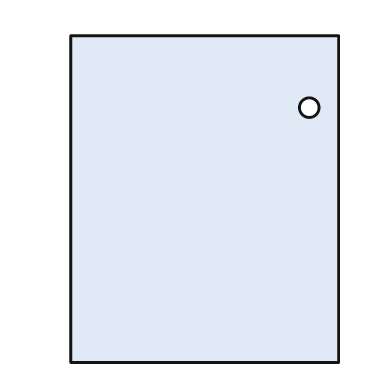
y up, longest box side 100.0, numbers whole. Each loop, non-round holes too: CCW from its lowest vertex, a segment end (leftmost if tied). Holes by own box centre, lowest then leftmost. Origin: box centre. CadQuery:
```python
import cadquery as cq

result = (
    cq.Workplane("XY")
    .moveTo(-41.0, -50.0)
    .lineTo(41.0, -50.0)
    .lineTo(41.0, 50.0)
    .lineTo(-41.0, 50.0)
    .close()
    .moveTo(32.0, 28.0)
    .circle(3.0)
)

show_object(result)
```